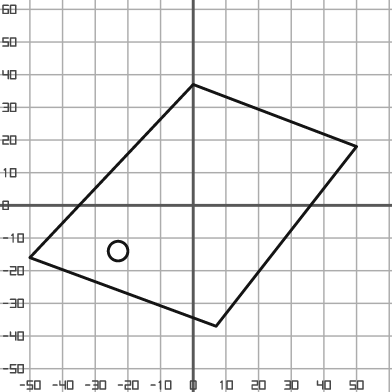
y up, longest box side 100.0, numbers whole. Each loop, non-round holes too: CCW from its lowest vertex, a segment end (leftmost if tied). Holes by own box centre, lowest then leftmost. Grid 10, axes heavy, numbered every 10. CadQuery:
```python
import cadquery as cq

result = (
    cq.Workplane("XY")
    .moveTo(7.0, -37.0)
    .lineTo(50.0, 18.0)
    .lineTo(0.0, 37.0)
    .lineTo(-50.0, -16.0)
    .close()
    .moveTo(-23.0, -14.0)
    .circle(3.0)
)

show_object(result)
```